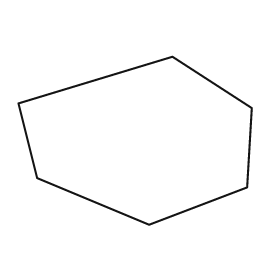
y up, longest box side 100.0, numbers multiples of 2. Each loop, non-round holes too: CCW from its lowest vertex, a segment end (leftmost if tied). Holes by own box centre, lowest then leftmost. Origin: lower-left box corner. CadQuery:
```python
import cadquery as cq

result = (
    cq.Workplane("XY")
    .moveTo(56.0, 0.0)
    .lineTo(98.0, 16.0)
    .lineTo(100.0, 50.0)
    .lineTo(66.0, 72.0)
    .lineTo(0.0, 52.0)
    .lineTo(8.0, 20.0)
    .close()
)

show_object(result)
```